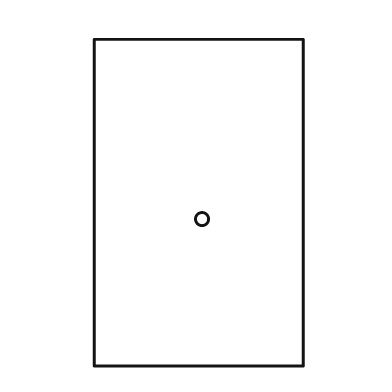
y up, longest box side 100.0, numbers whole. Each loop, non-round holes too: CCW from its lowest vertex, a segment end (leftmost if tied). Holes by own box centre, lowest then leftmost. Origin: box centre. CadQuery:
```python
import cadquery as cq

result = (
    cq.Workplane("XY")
    .moveTo(-32.0, -50.0)
    .lineTo(32.0, -50.0)
    .lineTo(32.0, 50.0)
    .lineTo(-32.0, 50.0)
    .close()
    .moveTo(1.0, -5.0)
    .circle(2.0)
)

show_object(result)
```